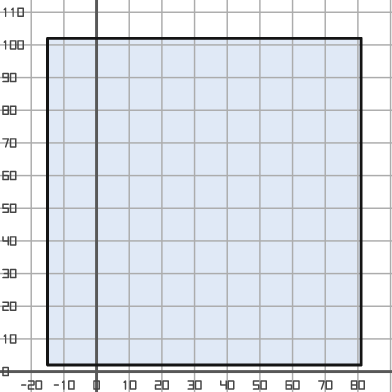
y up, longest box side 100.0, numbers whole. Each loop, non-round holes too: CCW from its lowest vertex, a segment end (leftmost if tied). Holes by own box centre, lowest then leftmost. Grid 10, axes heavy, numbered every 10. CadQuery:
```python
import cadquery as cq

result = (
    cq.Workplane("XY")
    .moveTo(-15.0, 2.0)
    .lineTo(81.0, 2.0)
    .lineTo(81.0, 102.0)
    .lineTo(-15.0, 102.0)
    .close()
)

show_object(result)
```